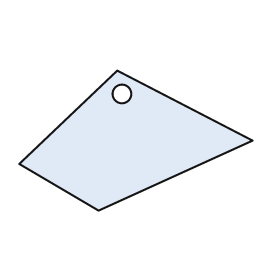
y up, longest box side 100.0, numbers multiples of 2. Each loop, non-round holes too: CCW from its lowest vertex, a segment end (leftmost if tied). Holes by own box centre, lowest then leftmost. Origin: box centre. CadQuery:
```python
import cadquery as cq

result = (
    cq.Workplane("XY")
    .moveTo(-16.0, -30.0)
    .lineTo(50.0, 0.0)
    .lineTo(-8.0, 30.0)
    .lineTo(-50.0, -10.0)
    .close()
    .moveTo(-6.0, 20.0)
    .circle(4.0)
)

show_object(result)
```